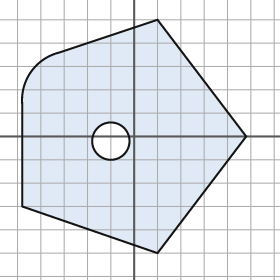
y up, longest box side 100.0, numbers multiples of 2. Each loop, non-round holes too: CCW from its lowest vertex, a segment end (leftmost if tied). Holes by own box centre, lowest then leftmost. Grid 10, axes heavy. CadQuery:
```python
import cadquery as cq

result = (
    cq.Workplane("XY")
    .moveTo(10.0, -50.0)
    .lineTo(48.0, 0.0)
    .lineTo(10.0, 50.0)
    .lineTo(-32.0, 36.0)
    .threePointArc((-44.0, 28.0), (-48.0, 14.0))
    .lineTo(-48.0, -30.0)
    .close()
    .moveTo(-10.0, -2.0)
    .circle(8.0)
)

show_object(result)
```